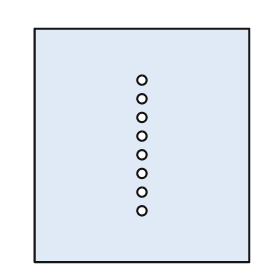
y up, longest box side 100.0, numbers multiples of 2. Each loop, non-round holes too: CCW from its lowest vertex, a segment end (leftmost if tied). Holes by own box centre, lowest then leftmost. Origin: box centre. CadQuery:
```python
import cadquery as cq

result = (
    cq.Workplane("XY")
    .moveTo(-46.0, -50.0)
    .lineTo(46.0, -50.0)
    .lineTo(46.0, 50.0)
    .lineTo(-46.0, 50.0)
    .close()
    .moveTo(0.0, -28.0)
    .circle(2.0)
    .moveTo(0.0, -20.0)
    .circle(2.0)
    .moveTo(0.0, -12.0)
    .circle(2.0)
    .moveTo(0.0, -4.0)
    .circle(2.0)
    .moveTo(0.0, 4.0)
    .circle(2.0)
    .moveTo(0.0, 12.0)
    .circle(2.0)
    .moveTo(0.0, 20.0)
    .circle(2.0)
    .moveTo(0.0, 28.0)
    .circle(2.0)
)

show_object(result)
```